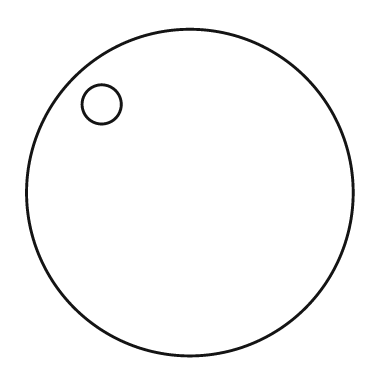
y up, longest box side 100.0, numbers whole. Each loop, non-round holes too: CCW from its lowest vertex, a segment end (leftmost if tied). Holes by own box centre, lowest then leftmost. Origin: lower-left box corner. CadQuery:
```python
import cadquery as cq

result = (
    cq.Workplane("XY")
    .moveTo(50.0, 50.0)
    .circle(50.0)
    .moveTo(23.0, 77.0)
    .circle(6.0)
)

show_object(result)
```